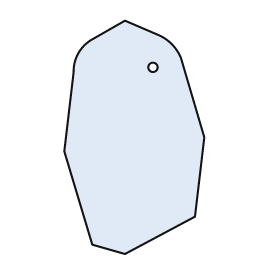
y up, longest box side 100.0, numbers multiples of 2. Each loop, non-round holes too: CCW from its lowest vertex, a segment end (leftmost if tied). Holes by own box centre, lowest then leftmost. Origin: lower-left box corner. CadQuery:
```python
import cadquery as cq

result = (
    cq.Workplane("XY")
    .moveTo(26.0, 0.0)
    .lineTo(56.0, 16.0)
    .lineTo(60.0, 50.0)
    .lineTo(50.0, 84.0)
    .threePointArc((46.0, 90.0), (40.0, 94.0))
    .lineTo(26.0, 100.0)
    .lineTo(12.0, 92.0)
    .threePointArc((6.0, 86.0), (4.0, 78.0))
    .lineTo(0.0, 44.0)
    .lineTo(12.0, 4.0)
    .close()
    .moveTo(38.0, 80.0)
    .circle(2.0)
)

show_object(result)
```